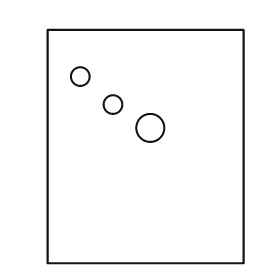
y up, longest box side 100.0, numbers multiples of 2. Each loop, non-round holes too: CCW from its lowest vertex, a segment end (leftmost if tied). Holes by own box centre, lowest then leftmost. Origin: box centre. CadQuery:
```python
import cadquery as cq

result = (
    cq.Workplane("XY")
    .moveTo(-42.0, -50.0)
    .lineTo(42.0, -50.0)
    .lineTo(42.0, 50.0)
    .lineTo(-42.0, 50.0)
    .close()
    .moveTo(2.0, 8.0)
    .circle(6.0)
    .moveTo(-14.0, 18.0)
    .circle(4.0)
    .moveTo(-28.0, 30.0)
    .circle(4.0)
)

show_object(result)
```